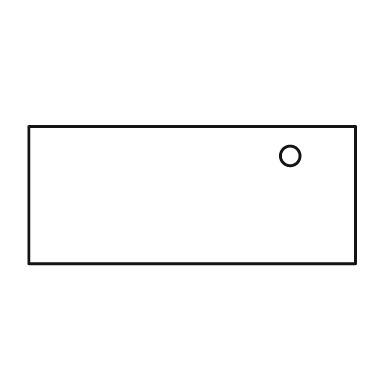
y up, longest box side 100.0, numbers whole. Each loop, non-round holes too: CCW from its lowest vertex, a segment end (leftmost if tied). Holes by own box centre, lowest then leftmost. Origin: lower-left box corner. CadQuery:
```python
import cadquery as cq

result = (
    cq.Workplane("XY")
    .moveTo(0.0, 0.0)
    .lineTo(100.0, 0.0)
    .lineTo(100.0, 42.0)
    .lineTo(0.0, 42.0)
    .close()
    .moveTo(80.0, 33.0)
    .circle(3.0)
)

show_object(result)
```